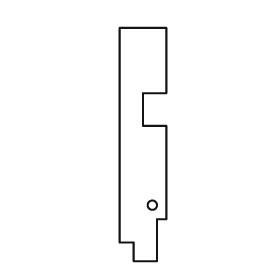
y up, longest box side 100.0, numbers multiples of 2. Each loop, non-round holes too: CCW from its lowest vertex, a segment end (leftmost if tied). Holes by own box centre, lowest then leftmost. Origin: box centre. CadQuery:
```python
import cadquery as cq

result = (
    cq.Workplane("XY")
    .moveTo(-4.0, -50.0)
    .lineTo(6.0, -50.0)
    .lineTo(6.0, -32.0)
    .lineTo(10.0, -32.0)
    .lineTo(10.0, 8.0)
    .lineTo(0.0, 8.0)
    .lineTo(0.0, 22.0)
    .lineTo(10.0, 22.0)
    .lineTo(10.0, 50.0)
    .lineTo(-10.0, 50.0)
    .lineTo(-10.0, -42.0)
    .lineTo(-4.0, -42.0)
    .close()
    .moveTo(4.0, -26.0)
    .circle(2.0)
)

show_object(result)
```